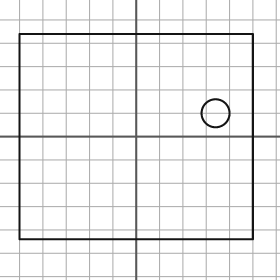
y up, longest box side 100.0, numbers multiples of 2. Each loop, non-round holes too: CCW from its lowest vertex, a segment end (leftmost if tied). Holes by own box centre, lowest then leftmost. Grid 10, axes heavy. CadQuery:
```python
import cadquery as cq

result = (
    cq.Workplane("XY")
    .moveTo(-50.0, -44.0)
    .lineTo(50.0, -44.0)
    .lineTo(50.0, 44.0)
    .lineTo(-50.0, 44.0)
    .close()
    .moveTo(34.0, 10.0)
    .circle(6.0)
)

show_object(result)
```